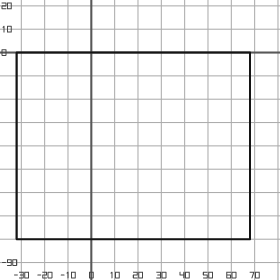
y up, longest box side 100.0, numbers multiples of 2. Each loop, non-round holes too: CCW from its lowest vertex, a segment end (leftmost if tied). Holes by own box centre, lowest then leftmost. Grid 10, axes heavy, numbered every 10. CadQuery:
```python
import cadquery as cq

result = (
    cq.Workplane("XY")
    .moveTo(-32.0, -80.0)
    .lineTo(68.0, -80.0)
    .lineTo(68.0, 0.0)
    .lineTo(-32.0, 0.0)
    .close()
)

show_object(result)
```